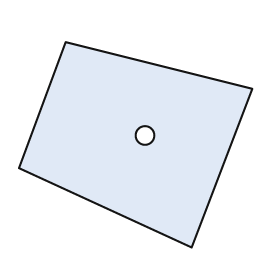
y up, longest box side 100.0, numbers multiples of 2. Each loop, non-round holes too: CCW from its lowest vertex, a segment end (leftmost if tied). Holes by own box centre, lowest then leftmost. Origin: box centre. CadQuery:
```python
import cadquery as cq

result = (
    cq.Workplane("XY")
    .moveTo(24.0, -44.0)
    .lineTo(50.0, 24.0)
    .lineTo(-30.0, 44.0)
    .lineTo(-50.0, -10.0)
    .close()
    .moveTo(4.0, 4.0)
    .circle(4.0)
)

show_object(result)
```